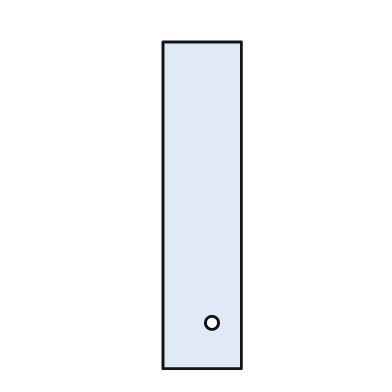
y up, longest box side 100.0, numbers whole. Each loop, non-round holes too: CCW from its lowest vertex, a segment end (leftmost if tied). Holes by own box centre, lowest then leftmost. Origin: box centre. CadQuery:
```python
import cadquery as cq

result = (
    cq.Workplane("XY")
    .moveTo(-12.0, -50.0)
    .lineTo(12.0, -50.0)
    .lineTo(12.0, 50.0)
    .lineTo(-12.0, 50.0)
    .close()
    .moveTo(3.0, -36.0)
    .circle(2.0)
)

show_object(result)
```